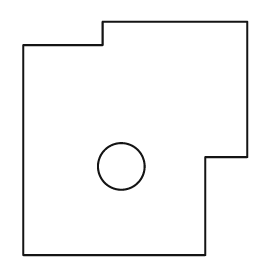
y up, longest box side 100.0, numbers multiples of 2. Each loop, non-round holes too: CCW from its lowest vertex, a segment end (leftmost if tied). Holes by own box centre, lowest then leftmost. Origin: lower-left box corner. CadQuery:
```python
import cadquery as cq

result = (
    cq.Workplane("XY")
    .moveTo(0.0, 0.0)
    .lineTo(78.0, 0.0)
    .lineTo(78.0, 42.0)
    .lineTo(96.0, 42.0)
    .lineTo(96.0, 100.0)
    .lineTo(34.0, 100.0)
    .lineTo(34.0, 90.0)
    .lineTo(0.0, 90.0)
    .close()
    .moveTo(42.0, 38.0)
    .circle(10.0)
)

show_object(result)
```